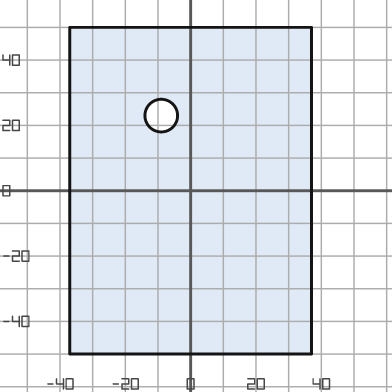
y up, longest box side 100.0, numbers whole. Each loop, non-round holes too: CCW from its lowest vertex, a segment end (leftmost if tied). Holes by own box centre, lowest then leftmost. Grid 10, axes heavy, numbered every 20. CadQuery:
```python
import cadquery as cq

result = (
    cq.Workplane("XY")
    .moveTo(-37.0, -50.0)
    .lineTo(37.0, -50.0)
    .lineTo(37.0, 50.0)
    .lineTo(-37.0, 50.0)
    .close()
    .moveTo(-9.0, 23.0)
    .circle(5.0)
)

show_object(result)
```